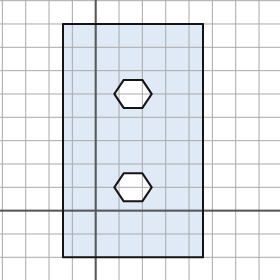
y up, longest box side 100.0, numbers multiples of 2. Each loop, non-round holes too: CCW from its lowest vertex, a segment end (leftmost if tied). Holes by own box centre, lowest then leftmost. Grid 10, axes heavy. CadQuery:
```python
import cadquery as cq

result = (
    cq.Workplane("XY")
    .moveTo(-14.0, -20.0)
    .lineTo(46.0, -20.0)
    .lineTo(46.0, 80.0)
    .lineTo(-14.0, 80.0)
    .close()
    .moveTo(12.0, 4.0)
    .lineTo(20.0, 4.0)
    .lineTo(24.0, 10.0)
    .lineTo(20.0, 16.0)
    .lineTo(12.0, 16.0)
    .lineTo(8.0, 10.0)
    .close()
    .moveTo(12.0, 44.0)
    .lineTo(20.0, 44.0)
    .lineTo(24.0, 50.0)
    .lineTo(20.0, 56.0)
    .lineTo(12.0, 56.0)
    .lineTo(8.0, 50.0)
    .close()
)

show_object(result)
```